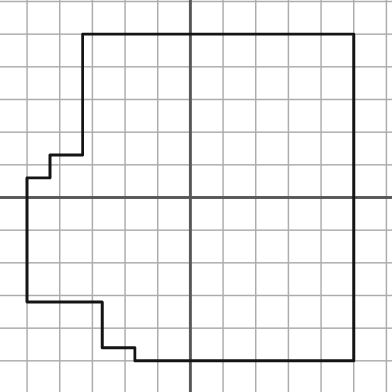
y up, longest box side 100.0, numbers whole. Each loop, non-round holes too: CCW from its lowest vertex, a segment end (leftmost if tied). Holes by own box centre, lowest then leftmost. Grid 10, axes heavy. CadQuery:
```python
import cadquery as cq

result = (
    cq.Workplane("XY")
    .moveTo(-17.0, -50.0)
    .lineTo(50.0, -50.0)
    .lineTo(50.0, 50.0)
    .lineTo(-33.0, 50.0)
    .lineTo(-33.0, 13.0)
    .lineTo(-43.0, 13.0)
    .lineTo(-43.0, 6.0)
    .lineTo(-50.0, 6.0)
    .lineTo(-50.0, -32.0)
    .lineTo(-27.0, -32.0)
    .lineTo(-27.0, -46.0)
    .lineTo(-17.0, -46.0)
    .close()
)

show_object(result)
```